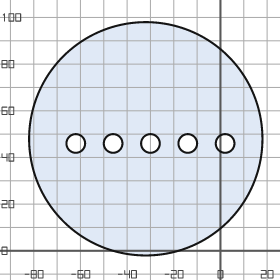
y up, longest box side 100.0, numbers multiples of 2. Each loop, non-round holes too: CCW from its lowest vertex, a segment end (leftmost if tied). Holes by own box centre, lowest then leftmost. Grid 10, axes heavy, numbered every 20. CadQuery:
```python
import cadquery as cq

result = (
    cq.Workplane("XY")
    .moveTo(-32.0, 48.0)
    .circle(50.0)
    .moveTo(-62.0, 46.0)
    .circle(4.0)
    .moveTo(-46.0, 46.0)
    .circle(4.0)
    .moveTo(-30.0, 46.0)
    .circle(4.0)
    .moveTo(-14.0, 46.0)
    .circle(4.0)
    .moveTo(2.0, 46.0)
    .circle(4.0)
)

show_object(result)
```